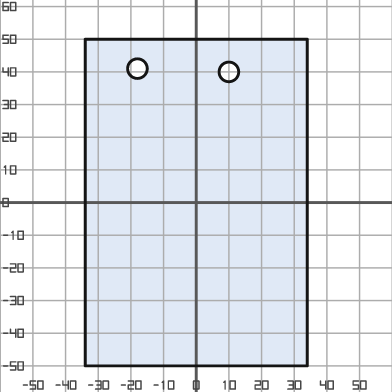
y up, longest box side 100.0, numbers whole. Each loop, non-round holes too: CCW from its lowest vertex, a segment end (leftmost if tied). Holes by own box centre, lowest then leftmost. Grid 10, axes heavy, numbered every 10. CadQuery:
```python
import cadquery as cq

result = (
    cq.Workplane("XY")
    .moveTo(-34.0, -50.0)
    .lineTo(34.0, -50.0)
    .lineTo(34.0, 50.0)
    .lineTo(-34.0, 50.0)
    .close()
    .moveTo(10.0, 40.0)
    .circle(3.0)
    .moveTo(-18.0, 41.0)
    .circle(3.0)
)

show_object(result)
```